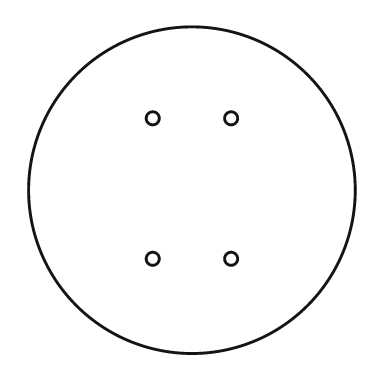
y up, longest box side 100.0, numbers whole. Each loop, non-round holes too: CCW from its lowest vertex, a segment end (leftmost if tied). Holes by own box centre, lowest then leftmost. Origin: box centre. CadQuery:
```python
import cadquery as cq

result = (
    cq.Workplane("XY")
    .moveTo(0.0, 0.0)
    .circle(50.0)
    .moveTo(-12.0, -21.0)
    .circle(2.0)
    .moveTo(12.0, -21.0)
    .circle(2.0)
    .moveTo(-12.0, 22.0)
    .circle(2.0)
    .moveTo(12.0, 22.0)
    .circle(2.0)
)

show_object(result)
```